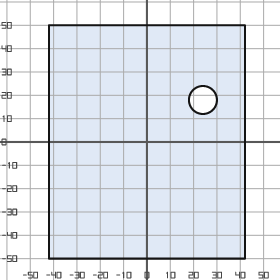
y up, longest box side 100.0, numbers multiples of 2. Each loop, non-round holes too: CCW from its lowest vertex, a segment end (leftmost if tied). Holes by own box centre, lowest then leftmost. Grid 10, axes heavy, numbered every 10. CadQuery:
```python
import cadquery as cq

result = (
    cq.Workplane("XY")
    .moveTo(-42.0, -50.0)
    .lineTo(42.0, -50.0)
    .lineTo(42.0, 50.0)
    .lineTo(-42.0, 50.0)
    .close()
    .moveTo(24.0, 18.0)
    .circle(6.0)
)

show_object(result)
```